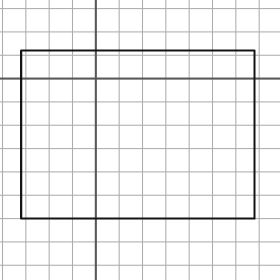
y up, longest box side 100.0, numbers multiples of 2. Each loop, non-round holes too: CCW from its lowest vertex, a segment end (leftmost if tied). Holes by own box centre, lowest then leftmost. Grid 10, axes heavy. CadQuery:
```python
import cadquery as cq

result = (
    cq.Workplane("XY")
    .moveTo(-32.0, -60.0)
    .lineTo(68.0, -60.0)
    .lineTo(68.0, 12.0)
    .lineTo(-32.0, 12.0)
    .close()
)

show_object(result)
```